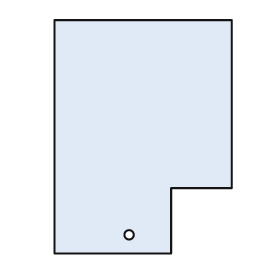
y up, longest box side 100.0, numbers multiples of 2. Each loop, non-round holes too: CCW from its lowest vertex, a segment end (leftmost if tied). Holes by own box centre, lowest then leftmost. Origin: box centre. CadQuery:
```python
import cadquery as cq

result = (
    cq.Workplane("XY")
    .moveTo(-38.0, -50.0)
    .lineTo(12.0, -50.0)
    .lineTo(12.0, -22.0)
    .lineTo(38.0, -22.0)
    .lineTo(38.0, 50.0)
    .lineTo(-38.0, 50.0)
    .close()
    .moveTo(-6.0, -42.0)
    .circle(2.0)
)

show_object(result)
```